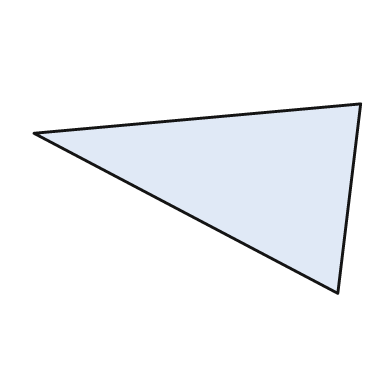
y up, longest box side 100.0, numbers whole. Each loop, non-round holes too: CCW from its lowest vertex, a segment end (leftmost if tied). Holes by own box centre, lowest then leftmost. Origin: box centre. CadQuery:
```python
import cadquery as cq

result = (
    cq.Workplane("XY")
    .moveTo(43.0, -29.0)
    .lineTo(50.0, 29.0)
    .lineTo(-50.0, 20.0)
    .close()
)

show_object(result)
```